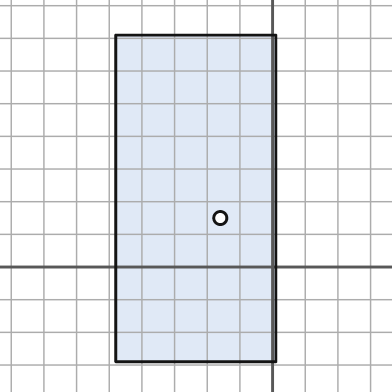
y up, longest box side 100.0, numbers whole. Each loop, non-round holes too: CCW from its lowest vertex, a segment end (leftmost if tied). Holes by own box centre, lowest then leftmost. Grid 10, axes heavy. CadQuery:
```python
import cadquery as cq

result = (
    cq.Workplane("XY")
    .moveTo(-48.0, -29.0)
    .lineTo(1.0, -29.0)
    .lineTo(1.0, 71.0)
    .lineTo(-48.0, 71.0)
    .close()
    .moveTo(-16.0, 15.0)
    .circle(2.0)
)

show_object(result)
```